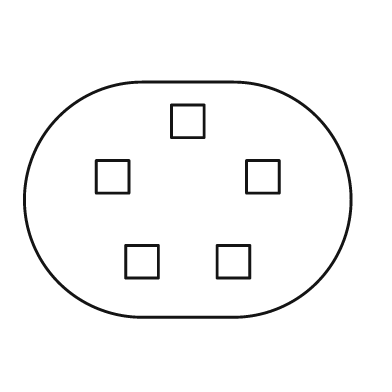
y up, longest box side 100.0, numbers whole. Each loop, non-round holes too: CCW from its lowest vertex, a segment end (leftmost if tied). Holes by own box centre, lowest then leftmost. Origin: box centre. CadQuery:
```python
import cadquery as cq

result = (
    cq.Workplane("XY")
    .moveTo(-14.0, -36.0)
    .lineTo(14.0, -36.0)
    .threePointArc((50.0, 0.0), (14.0, 36.0))
    .lineTo(-14.0, 36.0)
    .threePointArc((-50.0, 0.0), (-14.0, -36.0))
    .close()
    .moveTo(-19.0, -24.0)
    .lineTo(-9.0, -24.0)
    .lineTo(-9.0, -14.0)
    .lineTo(-19.0, -14.0)
    .close()
    .moveTo(9.0, -24.0)
    .lineTo(19.0, -24.0)
    .lineTo(19.0, -14.0)
    .lineTo(9.0, -14.0)
    .close()
    .moveTo(-28.0, 2.0)
    .lineTo(-18.0, 2.0)
    .lineTo(-18.0, 12.0)
    .lineTo(-28.0, 12.0)
    .close()
    .moveTo(18.0, 2.0)
    .lineTo(28.0, 2.0)
    .lineTo(28.0, 12.0)
    .lineTo(18.0, 12.0)
    .close()
    .moveTo(-5.0, 19.0)
    .lineTo(5.0, 19.0)
    .lineTo(5.0, 29.0)
    .lineTo(-5.0, 29.0)
    .close()
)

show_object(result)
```